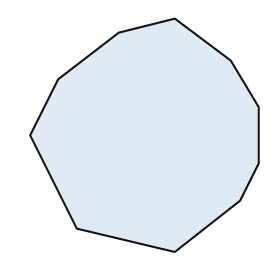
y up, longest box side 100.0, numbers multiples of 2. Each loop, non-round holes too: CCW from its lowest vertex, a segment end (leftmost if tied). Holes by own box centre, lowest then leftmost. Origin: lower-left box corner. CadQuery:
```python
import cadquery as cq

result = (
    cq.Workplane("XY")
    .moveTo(62.0, 0.0)
    .lineTo(90.0, 22.0)
    .lineTo(98.0, 38.0)
    .lineTo(98.0, 62.0)
    .lineTo(86.0, 82.0)
    .lineTo(62.0, 100.0)
    .lineTo(38.0, 94.0)
    .lineTo(12.0, 74.0)
    .lineTo(0.0, 50.0)
    .lineTo(20.0, 10.0)
    .close()
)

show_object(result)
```